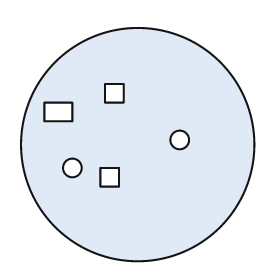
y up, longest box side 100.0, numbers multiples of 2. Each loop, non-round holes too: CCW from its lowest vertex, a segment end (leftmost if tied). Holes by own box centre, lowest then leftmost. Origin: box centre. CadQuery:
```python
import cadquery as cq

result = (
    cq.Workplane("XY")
    .moveTo(0.0, 0.0)
    .circle(50.0)
    .moveTo(-16.0, -18.0)
    .lineTo(-8.0, -18.0)
    .lineTo(-8.0, -10.0)
    .lineTo(-16.0, -10.0)
    .close()
    .moveTo(-28.0, -10.0)
    .circle(4.0)
    .moveTo(18.0, 2.0)
    .circle(4.0)
    .moveTo(-40.0, 10.0)
    .lineTo(-28.0, 10.0)
    .lineTo(-28.0, 18.0)
    .lineTo(-40.0, 18.0)
    .close()
    .moveTo(-14.0, 18.0)
    .lineTo(-6.0, 18.0)
    .lineTo(-6.0, 26.0)
    .lineTo(-14.0, 26.0)
    .close()
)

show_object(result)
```